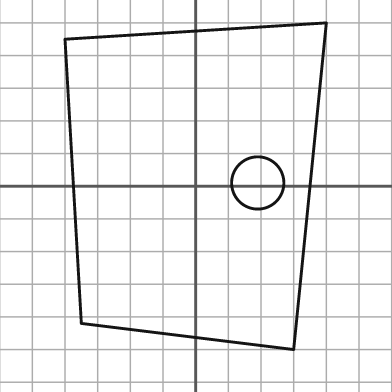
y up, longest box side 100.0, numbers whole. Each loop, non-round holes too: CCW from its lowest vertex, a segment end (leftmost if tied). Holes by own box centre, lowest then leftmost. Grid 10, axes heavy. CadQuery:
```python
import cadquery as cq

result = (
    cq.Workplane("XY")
    .moveTo(30.0, -50.0)
    .lineTo(40.0, 50.0)
    .lineTo(-40.0, 45.0)
    .lineTo(-35.0, -42.0)
    .close()
    .moveTo(19.0, 1.0)
    .circle(8.0)
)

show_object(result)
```